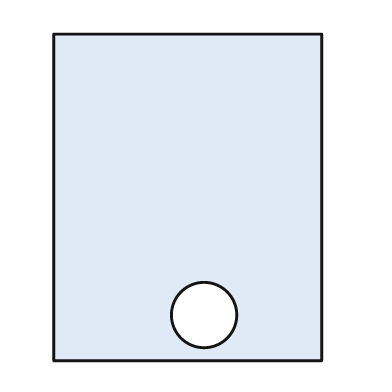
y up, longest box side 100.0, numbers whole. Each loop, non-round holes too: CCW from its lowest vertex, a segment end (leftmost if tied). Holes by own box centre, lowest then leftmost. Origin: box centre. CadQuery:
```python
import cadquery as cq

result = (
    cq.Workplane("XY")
    .moveTo(-41.0, -50.0)
    .lineTo(41.0, -50.0)
    .lineTo(41.0, 50.0)
    .lineTo(-41.0, 50.0)
    .close()
    .moveTo(5.0, -36.0)
    .circle(10.0)
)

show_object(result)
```